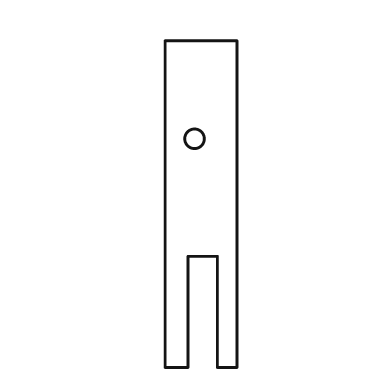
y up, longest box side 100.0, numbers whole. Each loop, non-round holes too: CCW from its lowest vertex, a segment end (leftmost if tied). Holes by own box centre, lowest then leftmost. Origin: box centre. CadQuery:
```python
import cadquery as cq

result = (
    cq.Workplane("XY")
    .moveTo(-11.0, -50.0)
    .lineTo(-4.0, -50.0)
    .lineTo(-4.0, -16.0)
    .lineTo(5.0, -16.0)
    .lineTo(5.0, -50.0)
    .lineTo(11.0, -50.0)
    .lineTo(11.0, 50.0)
    .lineTo(-11.0, 50.0)
    .close()
    .moveTo(-2.0, 20.0)
    .circle(3.0)
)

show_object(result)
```